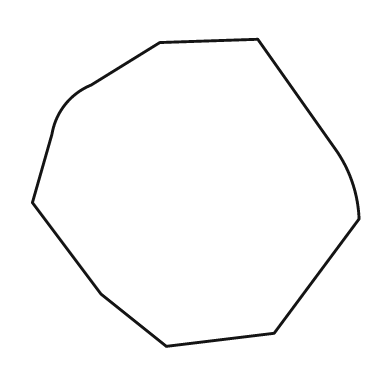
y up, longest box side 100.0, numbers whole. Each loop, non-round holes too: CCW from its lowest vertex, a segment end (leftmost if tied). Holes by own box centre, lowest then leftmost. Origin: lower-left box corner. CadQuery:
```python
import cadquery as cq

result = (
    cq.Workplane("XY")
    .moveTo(41.0, 0.0)
    .lineTo(74.0, 4.0)
    .lineTo(100.0, 39.0)
    .threePointArc((98.0, 50.0), (93.0, 60.0))
    .lineTo(69.0, 94.0)
    .lineTo(39.0, 93.0)
    .lineTo(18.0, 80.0)
    .threePointArc((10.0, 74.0), (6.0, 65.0))
    .lineTo(0.0, 44.0)
    .lineTo(21.0, 16.0)
    .close()
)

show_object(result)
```